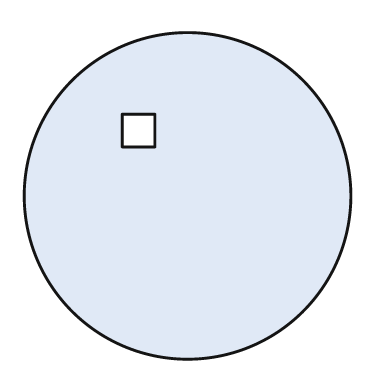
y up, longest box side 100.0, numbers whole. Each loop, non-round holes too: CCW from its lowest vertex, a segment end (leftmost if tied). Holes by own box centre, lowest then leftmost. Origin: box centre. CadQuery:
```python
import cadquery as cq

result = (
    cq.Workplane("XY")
    .moveTo(0.0, 0.0)
    .circle(50.0)
    .moveTo(-20.0, 15.0)
    .lineTo(-10.0, 15.0)
    .lineTo(-10.0, 25.0)
    .lineTo(-20.0, 25.0)
    .close()
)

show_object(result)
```